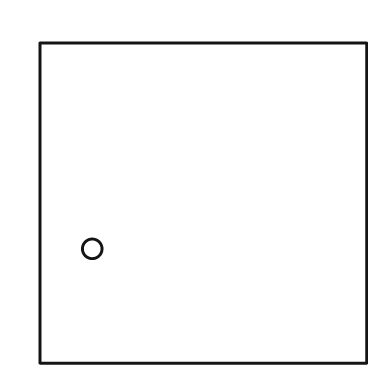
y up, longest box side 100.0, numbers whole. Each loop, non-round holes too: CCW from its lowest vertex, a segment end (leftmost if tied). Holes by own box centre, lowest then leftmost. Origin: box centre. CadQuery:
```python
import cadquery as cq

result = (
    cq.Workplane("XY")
    .moveTo(-50.0, -49.0)
    .lineTo(50.0, -49.0)
    .lineTo(50.0, 49.0)
    .lineTo(-50.0, 49.0)
    .close()
    .moveTo(-34.0, -14.0)
    .circle(3.0)
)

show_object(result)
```